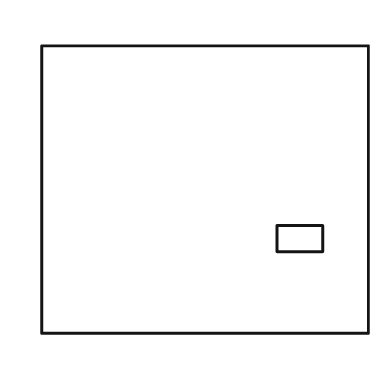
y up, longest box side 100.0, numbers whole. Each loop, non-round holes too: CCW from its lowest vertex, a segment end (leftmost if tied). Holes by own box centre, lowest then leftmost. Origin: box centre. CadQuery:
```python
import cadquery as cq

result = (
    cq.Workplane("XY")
    .moveTo(-50.0, -44.0)
    .lineTo(50.0, -44.0)
    .lineTo(50.0, 44.0)
    .lineTo(-50.0, 44.0)
    .close()
    .moveTo(22.0, -19.0)
    .lineTo(36.0, -19.0)
    .lineTo(36.0, -11.0)
    .lineTo(22.0, -11.0)
    .close()
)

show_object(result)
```